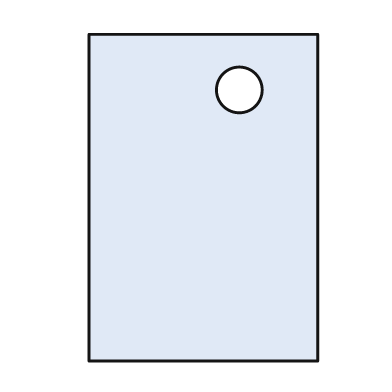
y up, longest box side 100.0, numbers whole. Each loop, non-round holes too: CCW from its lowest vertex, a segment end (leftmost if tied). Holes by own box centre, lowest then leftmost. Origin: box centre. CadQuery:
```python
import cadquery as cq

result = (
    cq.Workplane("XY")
    .moveTo(-35.0, -50.0)
    .lineTo(35.0, -50.0)
    .lineTo(35.0, 50.0)
    .lineTo(-35.0, 50.0)
    .close()
    .moveTo(11.0, 33.0)
    .circle(7.0)
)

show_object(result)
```